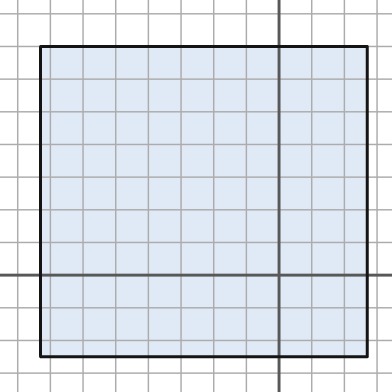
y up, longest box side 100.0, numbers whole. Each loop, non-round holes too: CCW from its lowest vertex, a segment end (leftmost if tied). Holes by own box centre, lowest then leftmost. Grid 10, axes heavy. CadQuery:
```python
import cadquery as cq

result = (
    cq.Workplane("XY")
    .moveTo(-73.0, -25.0)
    .lineTo(27.0, -25.0)
    .lineTo(27.0, 70.0)
    .lineTo(-73.0, 70.0)
    .close()
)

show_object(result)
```